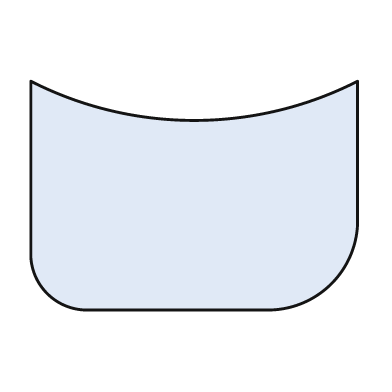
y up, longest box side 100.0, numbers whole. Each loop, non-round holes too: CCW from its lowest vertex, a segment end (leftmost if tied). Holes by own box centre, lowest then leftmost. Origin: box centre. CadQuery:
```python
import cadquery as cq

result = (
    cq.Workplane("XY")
    .moveTo(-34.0, -35.0)
    .lineTo(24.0, -35.0)
    .threePointArc((42.0, -27.0), (50.0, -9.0))
    .lineTo(50.0, 35.0)
    .threePointArc((0.0, 23.0), (-50.0, 35.0))
    .lineTo(-50.0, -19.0)
    .threePointArc((-45.0, -30.0), (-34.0, -35.0))
    .close()
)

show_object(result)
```